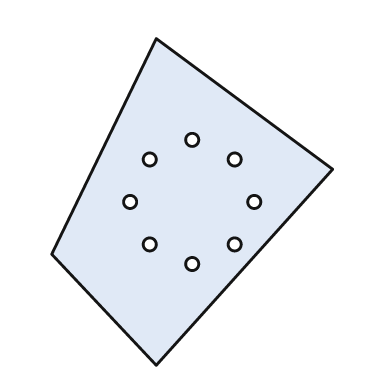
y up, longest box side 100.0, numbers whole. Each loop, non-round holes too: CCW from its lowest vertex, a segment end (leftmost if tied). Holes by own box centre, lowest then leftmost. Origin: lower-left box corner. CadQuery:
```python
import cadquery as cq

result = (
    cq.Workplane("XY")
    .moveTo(32.0, 0.0)
    .lineTo(86.0, 60.0)
    .lineTo(32.0, 100.0)
    .lineTo(0.0, 34.0)
    .close()
    .moveTo(43.0, 31.0)
    .circle(2.0)
    .moveTo(30.0, 37.0)
    .circle(2.0)
    .moveTo(56.0, 37.0)
    .circle(2.0)
    .moveTo(24.0, 50.0)
    .circle(2.0)
    .moveTo(62.0, 50.0)
    .circle(2.0)
    .moveTo(30.0, 63.0)
    .circle(2.0)
    .moveTo(56.0, 63.0)
    .circle(2.0)
    .moveTo(43.0, 69.0)
    .circle(2.0)
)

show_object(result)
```